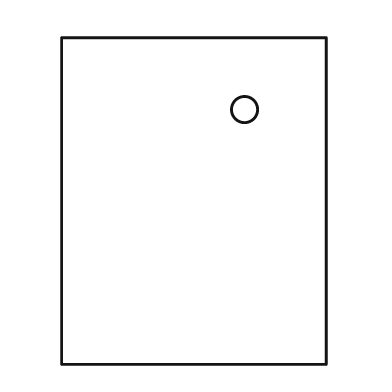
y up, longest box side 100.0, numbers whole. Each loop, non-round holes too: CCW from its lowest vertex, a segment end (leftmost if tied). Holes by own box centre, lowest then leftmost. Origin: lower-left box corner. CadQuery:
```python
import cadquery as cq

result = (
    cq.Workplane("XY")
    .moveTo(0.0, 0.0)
    .lineTo(81.0, 0.0)
    .lineTo(81.0, 100.0)
    .lineTo(0.0, 100.0)
    .close()
    .moveTo(56.0, 78.0)
    .circle(4.0)
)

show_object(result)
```